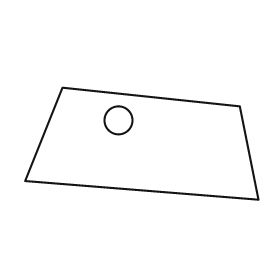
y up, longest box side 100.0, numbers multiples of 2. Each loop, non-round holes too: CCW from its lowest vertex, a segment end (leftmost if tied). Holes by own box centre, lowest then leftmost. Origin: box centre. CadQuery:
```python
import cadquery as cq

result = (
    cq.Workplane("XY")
    .moveTo(50.0, -24.0)
    .lineTo(42.0, 16.0)
    .lineTo(-34.0, 24.0)
    .lineTo(-50.0, -16.0)
    .close()
    .moveTo(-10.0, 10.0)
    .circle(6.0)
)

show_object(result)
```